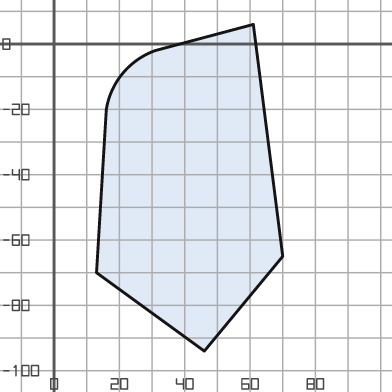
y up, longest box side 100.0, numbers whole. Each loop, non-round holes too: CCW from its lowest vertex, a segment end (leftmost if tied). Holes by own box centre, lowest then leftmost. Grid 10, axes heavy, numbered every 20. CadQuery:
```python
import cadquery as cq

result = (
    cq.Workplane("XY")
    .moveTo(46.0, -94.0)
    .lineTo(70.0, -65.0)
    .lineTo(61.0, 6.0)
    .lineTo(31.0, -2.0)
    .threePointArc((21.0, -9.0), (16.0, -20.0))
    .lineTo(13.0, -70.0)
    .close()
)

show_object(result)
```